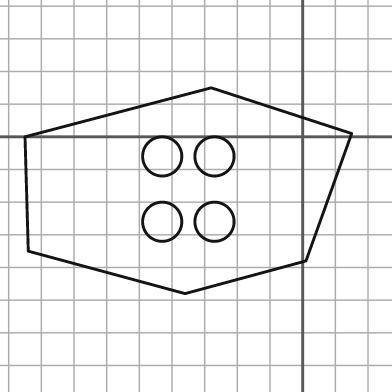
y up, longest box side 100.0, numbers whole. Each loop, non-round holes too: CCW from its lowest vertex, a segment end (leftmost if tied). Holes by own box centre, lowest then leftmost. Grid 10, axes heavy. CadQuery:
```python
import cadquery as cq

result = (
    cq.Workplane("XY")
    .moveTo(-36.0, -48.0)
    .lineTo(1.0, -38.0)
    .lineTo(15.0, 1.0)
    .lineTo(-28.0, 15.0)
    .lineTo(-85.0, 0.0)
    .lineTo(-84.0, -35.0)
    .close()
    .moveTo(-43.0, -26.0)
    .circle(6.0)
    .moveTo(-27.0, -26.0)
    .circle(6.0)
    .moveTo(-43.0, -6.0)
    .circle(6.0)
    .moveTo(-27.0, -6.0)
    .circle(6.0)
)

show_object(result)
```